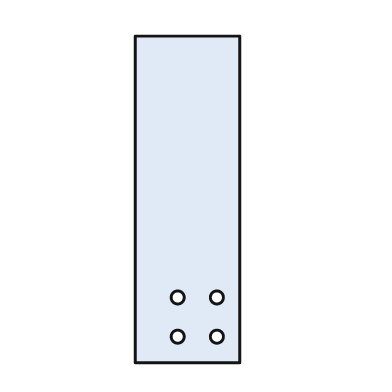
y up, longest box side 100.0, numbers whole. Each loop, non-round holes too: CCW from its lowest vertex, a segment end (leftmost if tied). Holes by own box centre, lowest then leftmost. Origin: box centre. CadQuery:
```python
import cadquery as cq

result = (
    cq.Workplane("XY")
    .moveTo(-16.0, -50.0)
    .lineTo(16.0, -50.0)
    .lineTo(16.0, 50.0)
    .lineTo(-16.0, 50.0)
    .close()
    .moveTo(-3.0, -42.0)
    .circle(2.0)
    .moveTo(9.0, -42.0)
    .circle(2.0)
    .moveTo(-3.0, -30.0)
    .circle(2.0)
    .moveTo(9.0, -30.0)
    .circle(2.0)
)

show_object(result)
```